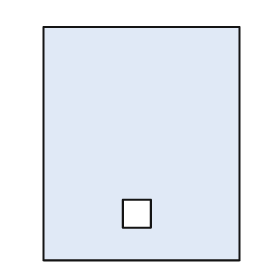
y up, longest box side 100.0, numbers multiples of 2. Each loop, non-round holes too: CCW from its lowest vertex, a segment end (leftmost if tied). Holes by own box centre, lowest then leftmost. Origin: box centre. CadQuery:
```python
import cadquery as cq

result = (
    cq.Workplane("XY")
    .moveTo(-42.0, -50.0)
    .lineTo(42.0, -50.0)
    .lineTo(42.0, 50.0)
    .lineTo(-42.0, 50.0)
    .close()
    .moveTo(-8.0, -36.0)
    .lineTo(4.0, -36.0)
    .lineTo(4.0, -24.0)
    .lineTo(-8.0, -24.0)
    .close()
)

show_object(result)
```